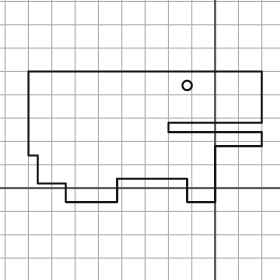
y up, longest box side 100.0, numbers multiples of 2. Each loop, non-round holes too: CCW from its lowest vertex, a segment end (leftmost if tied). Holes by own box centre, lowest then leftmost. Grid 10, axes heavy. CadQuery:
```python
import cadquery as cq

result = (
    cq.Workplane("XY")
    .moveTo(-64.0, -6.0)
    .lineTo(-42.0, -6.0)
    .lineTo(-42.0, 4.0)
    .lineTo(-12.0, 4.0)
    .lineTo(-12.0, -6.0)
    .lineTo(0.0, -6.0)
    .lineTo(0.0, 18.0)
    .lineTo(20.0, 18.0)
    .lineTo(20.0, 24.0)
    .lineTo(-20.0, 24.0)
    .lineTo(-20.0, 28.0)
    .lineTo(20.0, 28.0)
    .lineTo(20.0, 50.0)
    .lineTo(-80.0, 50.0)
    .lineTo(-80.0, 14.0)
    .lineTo(-76.0, 14.0)
    .lineTo(-76.0, 2.0)
    .lineTo(-64.0, 2.0)
    .close()
    .moveTo(-12.0, 44.0)
    .circle(2.0)
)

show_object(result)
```